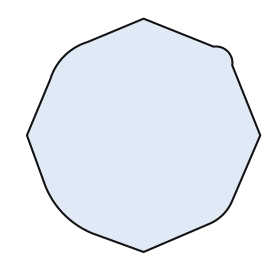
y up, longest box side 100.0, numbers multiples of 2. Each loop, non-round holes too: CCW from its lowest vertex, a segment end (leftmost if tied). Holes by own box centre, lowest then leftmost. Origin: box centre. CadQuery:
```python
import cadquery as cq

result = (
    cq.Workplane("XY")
    .moveTo(0.0, -50.0)
    .lineTo(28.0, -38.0)
    .threePointArc((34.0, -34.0), (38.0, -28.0))
    .lineTo(50.0, 0.0)
    .lineTo(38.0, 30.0)
    .threePointArc((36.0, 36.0), (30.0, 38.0))
    .lineTo(0.0, 50.0)
    .lineTo(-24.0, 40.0)
    .threePointArc((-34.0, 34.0), (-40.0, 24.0))
    .lineTo(-50.0, 0.0)
    .lineTo(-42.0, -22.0)
    .threePointArc((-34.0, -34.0), (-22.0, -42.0))
    .close()
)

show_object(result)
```